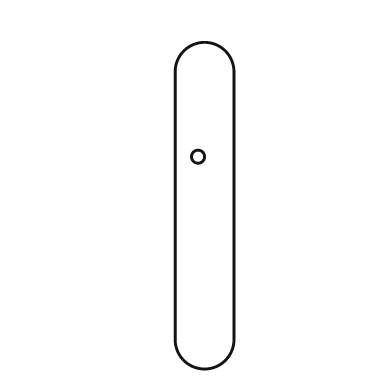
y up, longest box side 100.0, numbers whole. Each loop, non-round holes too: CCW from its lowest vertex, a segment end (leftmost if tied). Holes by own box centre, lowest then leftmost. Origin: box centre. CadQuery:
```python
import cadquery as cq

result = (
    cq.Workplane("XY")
    .moveTo(-9.0, -41.0)
    .threePointArc((0.0, -50.0), (9.0, -41.0))
    .lineTo(9.0, 41.0)
    .threePointArc((0.0, 50.0), (-9.0, 41.0))
    .close()
    .moveTo(-2.0, 15.0)
    .circle(2.0)
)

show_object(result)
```